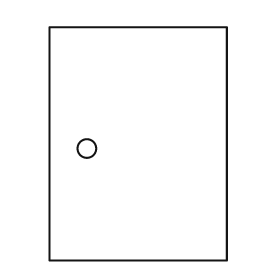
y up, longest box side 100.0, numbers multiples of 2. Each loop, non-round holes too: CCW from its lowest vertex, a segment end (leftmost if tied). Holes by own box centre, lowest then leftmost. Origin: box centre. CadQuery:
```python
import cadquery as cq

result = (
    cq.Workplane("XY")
    .moveTo(-38.0, -50.0)
    .lineTo(38.0, -50.0)
    .lineTo(38.0, 50.0)
    .lineTo(-38.0, 50.0)
    .close()
    .moveTo(-22.0, -2.0)
    .circle(4.0)
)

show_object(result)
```